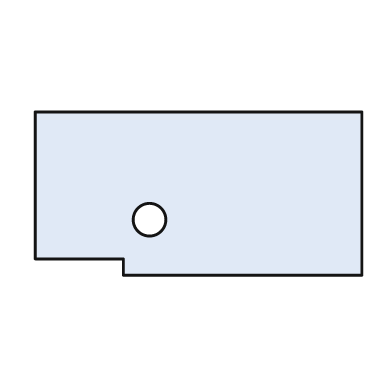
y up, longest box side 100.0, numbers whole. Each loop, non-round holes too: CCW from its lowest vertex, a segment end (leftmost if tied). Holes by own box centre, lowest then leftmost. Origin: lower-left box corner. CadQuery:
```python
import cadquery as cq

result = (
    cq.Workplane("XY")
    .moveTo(27.0, 0.0)
    .lineTo(100.0, 0.0)
    .lineTo(100.0, 50.0)
    .lineTo(0.0, 50.0)
    .lineTo(0.0, 5.0)
    .lineTo(27.0, 5.0)
    .close()
    .moveTo(35.0, 17.0)
    .circle(5.0)
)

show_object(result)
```